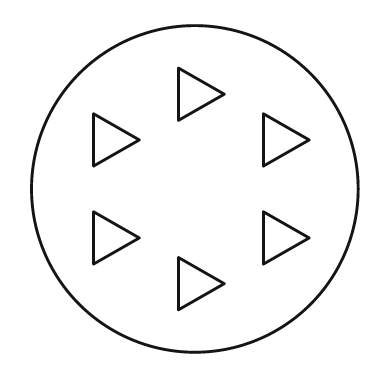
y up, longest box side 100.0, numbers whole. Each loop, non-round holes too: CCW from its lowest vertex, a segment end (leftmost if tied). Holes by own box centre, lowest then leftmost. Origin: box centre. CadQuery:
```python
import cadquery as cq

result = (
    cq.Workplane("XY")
    .moveTo(0.0, 0.0)
    .circle(50.0)
    .moveTo(-5.0, -37.0)
    .lineTo(9.0, -29.0)
    .lineTo(-5.0, -21.0)
    .close()
    .moveTo(-31.0, -23.0)
    .lineTo(-17.0, -15.0)
    .lineTo(-31.0, -7.0)
    .close()
    .moveTo(21.0, -23.0)
    .lineTo(35.0, -15.0)
    .lineTo(21.0, -7.0)
    .close()
    .moveTo(-31.0, 7.0)
    .lineTo(-17.0, 15.0)
    .lineTo(-31.0, 23.0)
    .close()
    .moveTo(21.0, 7.0)
    .lineTo(35.0, 15.0)
    .lineTo(21.0, 23.0)
    .close()
    .moveTo(-5.0, 21.0)
    .lineTo(9.0, 29.0)
    .lineTo(-5.0, 37.0)
    .close()
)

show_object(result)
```